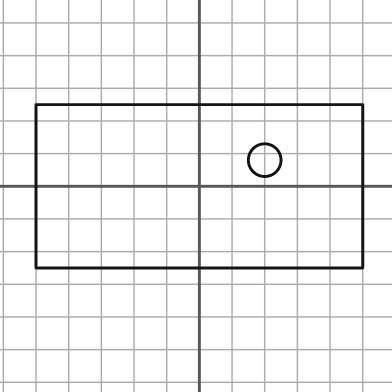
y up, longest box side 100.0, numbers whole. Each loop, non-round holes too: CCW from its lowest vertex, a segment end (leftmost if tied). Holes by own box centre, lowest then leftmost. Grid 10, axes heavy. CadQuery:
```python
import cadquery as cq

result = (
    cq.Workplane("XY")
    .moveTo(-50.0, -25.0)
    .lineTo(50.0, -25.0)
    .lineTo(50.0, 25.0)
    .lineTo(-50.0, 25.0)
    .close()
    .moveTo(20.0, 8.0)
    .circle(5.0)
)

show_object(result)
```